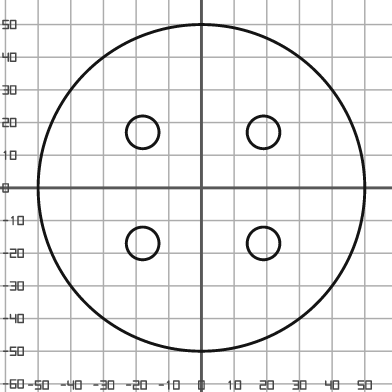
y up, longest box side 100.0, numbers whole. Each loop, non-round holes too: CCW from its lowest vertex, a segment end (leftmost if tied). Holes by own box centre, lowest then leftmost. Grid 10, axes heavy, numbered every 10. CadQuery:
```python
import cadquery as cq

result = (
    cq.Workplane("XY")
    .moveTo(0.0, 0.0)
    .circle(50.0)
    .moveTo(-18.0, -17.0)
    .circle(5.0)
    .moveTo(19.0, -17.0)
    .circle(5.0)
    .moveTo(-18.0, 17.0)
    .circle(5.0)
    .moveTo(19.0, 17.0)
    .circle(5.0)
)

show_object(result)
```